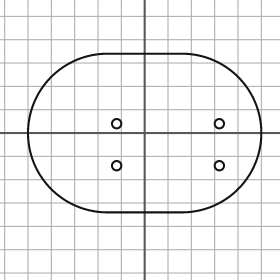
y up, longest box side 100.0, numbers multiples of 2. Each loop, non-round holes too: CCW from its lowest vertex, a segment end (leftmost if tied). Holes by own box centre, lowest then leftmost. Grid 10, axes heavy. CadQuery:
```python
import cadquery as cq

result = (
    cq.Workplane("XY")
    .moveTo(-16.0, -34.0)
    .lineTo(16.0, -34.0)
    .threePointArc((50.0, 0.0), (16.0, 34.0))
    .lineTo(-16.0, 34.0)
    .threePointArc((-50.0, 0.0), (-16.0, -34.0))
    .close()
    .moveTo(-12.0, -14.0)
    .circle(2.0)
    .moveTo(32.0, -14.0)
    .circle(2.0)
    .moveTo(-12.0, 4.0)
    .circle(2.0)
    .moveTo(32.0, 4.0)
    .circle(2.0)
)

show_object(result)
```